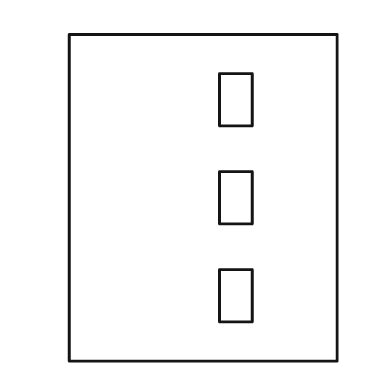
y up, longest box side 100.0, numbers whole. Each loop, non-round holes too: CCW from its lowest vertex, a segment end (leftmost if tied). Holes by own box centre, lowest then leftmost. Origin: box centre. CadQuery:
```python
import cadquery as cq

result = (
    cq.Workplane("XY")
    .moveTo(-41.0, -50.0)
    .lineTo(41.0, -50.0)
    .lineTo(41.0, 50.0)
    .lineTo(-41.0, 50.0)
    .close()
    .moveTo(5.0, -38.0)
    .lineTo(15.0, -38.0)
    .lineTo(15.0, -22.0)
    .lineTo(5.0, -22.0)
    .close()
    .moveTo(5.0, -8.0)
    .lineTo(15.0, -8.0)
    .lineTo(15.0, 8.0)
    .lineTo(5.0, 8.0)
    .close()
    .moveTo(5.0, 22.0)
    .lineTo(15.0, 22.0)
    .lineTo(15.0, 38.0)
    .lineTo(5.0, 38.0)
    .close()
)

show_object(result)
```